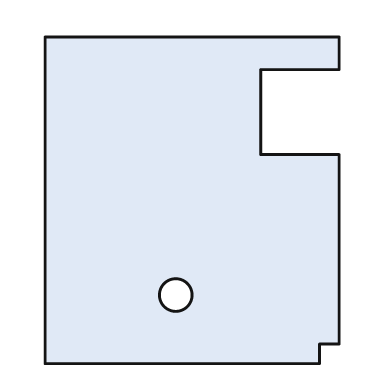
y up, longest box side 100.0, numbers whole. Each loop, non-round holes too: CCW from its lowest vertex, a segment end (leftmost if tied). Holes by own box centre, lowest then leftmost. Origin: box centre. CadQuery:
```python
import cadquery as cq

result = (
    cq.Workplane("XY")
    .moveTo(-45.0, -50.0)
    .lineTo(39.0, -50.0)
    .lineTo(39.0, -44.0)
    .lineTo(45.0, -44.0)
    .lineTo(45.0, 14.0)
    .lineTo(21.0, 14.0)
    .lineTo(21.0, 40.0)
    .lineTo(45.0, 40.0)
    .lineTo(45.0, 50.0)
    .lineTo(-45.0, 50.0)
    .close()
    .moveTo(-5.0, -29.0)
    .circle(5.0)
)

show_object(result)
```